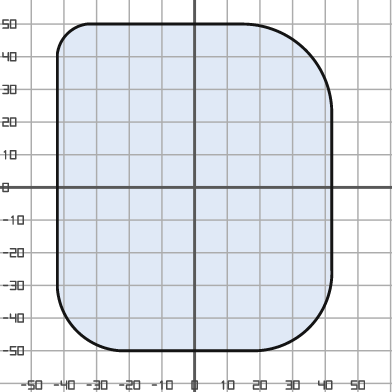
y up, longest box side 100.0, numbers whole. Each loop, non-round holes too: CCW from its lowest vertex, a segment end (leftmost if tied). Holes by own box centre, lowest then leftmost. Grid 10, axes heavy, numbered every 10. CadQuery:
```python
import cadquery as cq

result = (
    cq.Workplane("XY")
    .moveTo(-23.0, -50.0)
    .lineTo(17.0, -50.0)
    .threePointArc((35.0, -43.0), (42.0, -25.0))
    .lineTo(42.0, 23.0)
    .threePointArc((34.0, 42.0), (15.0, 50.0))
    .lineTo(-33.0, 50.0)
    .threePointArc((-39.0, 47.0), (-42.0, 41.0))
    .lineTo(-42.0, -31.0)
    .threePointArc((-36.0, -44.0), (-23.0, -50.0))
    .close()
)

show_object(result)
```